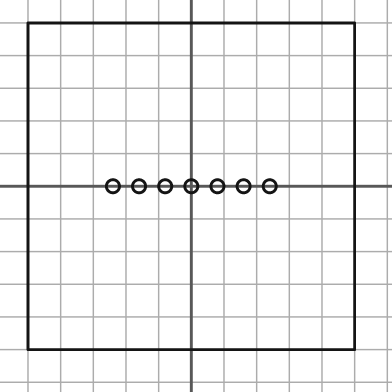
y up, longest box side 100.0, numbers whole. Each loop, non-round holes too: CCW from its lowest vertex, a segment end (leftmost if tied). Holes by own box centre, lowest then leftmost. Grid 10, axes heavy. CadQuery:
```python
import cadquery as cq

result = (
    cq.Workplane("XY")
    .moveTo(-50.0, -50.0)
    .lineTo(50.0, -50.0)
    .lineTo(50.0, 50.0)
    .lineTo(-50.0, 50.0)
    .close()
    .moveTo(-24.0, 0.0)
    .circle(2.0)
    .moveTo(-16.0, 0.0)
    .circle(2.0)
    .moveTo(-8.0, 0.0)
    .circle(2.0)
    .moveTo(0.0, 0.0)
    .circle(2.0)
    .moveTo(8.0, 0.0)
    .circle(2.0)
    .moveTo(16.0, 0.0)
    .circle(2.0)
    .moveTo(24.0, 0.0)
    .circle(2.0)
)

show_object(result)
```